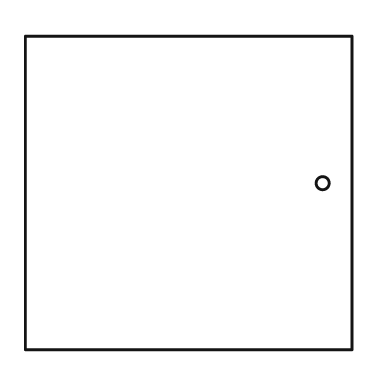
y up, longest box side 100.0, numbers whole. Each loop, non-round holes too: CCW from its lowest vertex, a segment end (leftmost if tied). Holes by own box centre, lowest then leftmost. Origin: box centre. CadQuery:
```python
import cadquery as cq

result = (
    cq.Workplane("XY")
    .moveTo(-50.0, -48.0)
    .lineTo(50.0, -48.0)
    .lineTo(50.0, 48.0)
    .lineTo(-50.0, 48.0)
    .close()
    .moveTo(41.0, 3.0)
    .circle(2.0)
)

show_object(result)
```